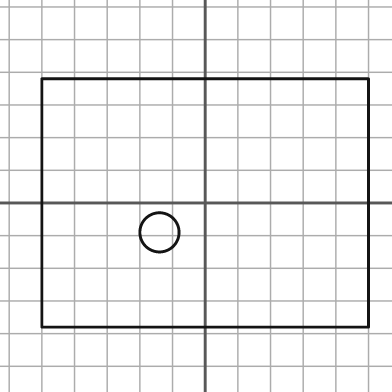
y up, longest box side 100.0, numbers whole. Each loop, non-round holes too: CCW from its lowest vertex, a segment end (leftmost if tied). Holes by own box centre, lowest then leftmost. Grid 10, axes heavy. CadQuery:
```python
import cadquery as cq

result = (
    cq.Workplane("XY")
    .moveTo(-50.0, -38.0)
    .lineTo(50.0, -38.0)
    .lineTo(50.0, 38.0)
    .lineTo(-50.0, 38.0)
    .close()
    .moveTo(-14.0, -9.0)
    .circle(6.0)
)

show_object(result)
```